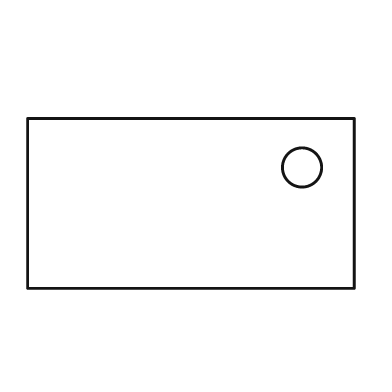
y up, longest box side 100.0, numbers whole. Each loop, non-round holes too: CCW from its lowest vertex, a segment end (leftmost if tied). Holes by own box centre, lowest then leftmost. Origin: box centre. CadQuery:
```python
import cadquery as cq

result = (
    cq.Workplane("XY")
    .moveTo(-50.0, -26.0)
    .lineTo(50.0, -26.0)
    .lineTo(50.0, 26.0)
    .lineTo(-50.0, 26.0)
    .close()
    .moveTo(34.0, 11.0)
    .circle(6.0)
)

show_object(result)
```